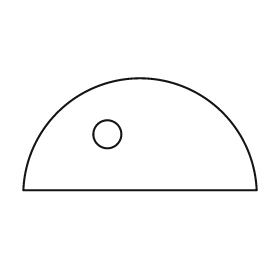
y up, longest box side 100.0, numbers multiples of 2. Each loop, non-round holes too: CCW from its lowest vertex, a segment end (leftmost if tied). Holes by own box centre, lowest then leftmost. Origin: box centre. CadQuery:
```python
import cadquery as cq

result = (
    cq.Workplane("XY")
    .moveTo(-50.0, -24.0)
    .lineTo(50.0, -24.0)
    .threePointArc((0.0, 24.0), (-50.0, -24.0))
    .close()
    .moveTo(-14.0, 0.0)
    .circle(6.0)
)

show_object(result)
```